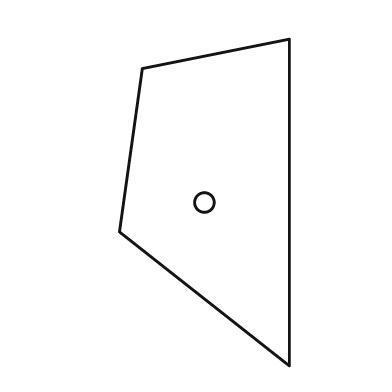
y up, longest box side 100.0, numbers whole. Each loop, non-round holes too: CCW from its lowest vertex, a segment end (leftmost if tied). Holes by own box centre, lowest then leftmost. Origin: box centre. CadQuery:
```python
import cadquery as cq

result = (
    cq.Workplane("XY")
    .moveTo(26.0, -50.0)
    .lineTo(26.0, 50.0)
    .lineTo(-19.0, 41.0)
    .lineTo(-26.0, -9.0)
    .close()
    .moveTo(0.0, 0.0)
    .circle(3.0)
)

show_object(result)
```